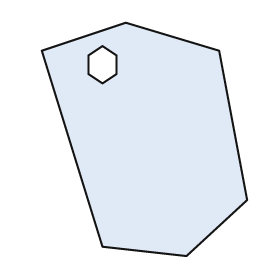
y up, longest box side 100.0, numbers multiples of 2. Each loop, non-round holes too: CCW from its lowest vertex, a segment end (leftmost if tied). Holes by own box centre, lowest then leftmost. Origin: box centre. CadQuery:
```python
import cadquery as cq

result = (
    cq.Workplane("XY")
    .moveTo(18.0, -50.0)
    .lineTo(44.0, -26.0)
    .lineTo(32.0, 38.0)
    .lineTo(-8.0, 50.0)
    .lineTo(-44.0, 38.0)
    .lineTo(-18.0, -46.0)
    .close()
    .moveTo(-18.0, 24.0)
    .lineTo(-12.0, 28.0)
    .lineTo(-12.0, 36.0)
    .lineTo(-18.0, 40.0)
    .lineTo(-24.0, 36.0)
    .lineTo(-24.0, 28.0)
    .close()
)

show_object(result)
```